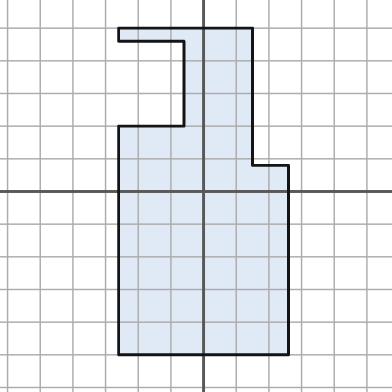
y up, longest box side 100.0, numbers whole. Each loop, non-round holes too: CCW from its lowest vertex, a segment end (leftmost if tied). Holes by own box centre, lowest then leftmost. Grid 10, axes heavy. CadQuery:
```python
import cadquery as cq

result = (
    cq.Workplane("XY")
    .moveTo(-26.0, -50.0)
    .lineTo(26.0, -50.0)
    .lineTo(26.0, 8.0)
    .lineTo(15.0, 8.0)
    .lineTo(15.0, 50.0)
    .lineTo(-26.0, 50.0)
    .lineTo(-26.0, 46.0)
    .lineTo(-6.0, 46.0)
    .lineTo(-6.0, 20.0)
    .lineTo(-26.0, 20.0)
    .close()
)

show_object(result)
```